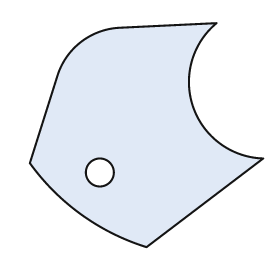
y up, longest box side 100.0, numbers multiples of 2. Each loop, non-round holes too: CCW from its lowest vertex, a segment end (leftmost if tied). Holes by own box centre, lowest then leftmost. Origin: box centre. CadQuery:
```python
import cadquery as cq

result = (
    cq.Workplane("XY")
    .moveTo(0.0, -48.0)
    .lineTo(50.0, -10.0)
    .threePointArc((20.0, 12.0), (30.0, 48.0))
    .lineTo(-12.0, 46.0)
    .threePointArc((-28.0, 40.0), (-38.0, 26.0))
    .lineTo(-50.0, -12.0)
    .threePointArc((-28.0, -34.0), (0.0, -48.0))
    .close()
    .moveTo(-20.0, -16.0)
    .circle(6.0)
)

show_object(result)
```